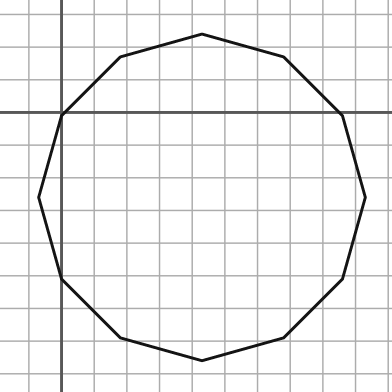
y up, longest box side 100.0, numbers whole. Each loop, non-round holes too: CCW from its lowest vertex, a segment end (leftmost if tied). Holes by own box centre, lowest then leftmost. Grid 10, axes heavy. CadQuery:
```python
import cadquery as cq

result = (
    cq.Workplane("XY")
    .moveTo(43.0, -76.0)
    .lineTo(68.0, -69.0)
    .lineTo(86.0, -51.0)
    .lineTo(93.0, -26.0)
    .lineTo(86.0, -1.0)
    .lineTo(68.0, 17.0)
    .lineTo(43.0, 24.0)
    .lineTo(18.0, 17.0)
    .lineTo(0.0, -1.0)
    .lineTo(-7.0, -26.0)
    .lineTo(0.0, -51.0)
    .lineTo(18.0, -69.0)
    .close()
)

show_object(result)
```